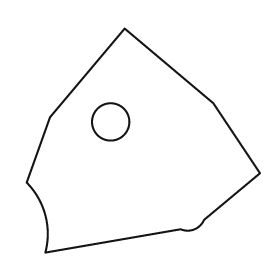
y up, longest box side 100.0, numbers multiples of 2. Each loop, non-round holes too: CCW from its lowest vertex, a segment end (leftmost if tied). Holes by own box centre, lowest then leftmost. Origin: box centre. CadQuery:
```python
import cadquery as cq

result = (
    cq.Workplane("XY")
    .moveTo(-42.0, -48.0)
    .lineTo(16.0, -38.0)
    .threePointArc((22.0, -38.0), (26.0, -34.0))
    .lineTo(50.0, -14.0)
    .lineTo(30.0, 16.0)
    .lineTo(-8.0, 48.0)
    .lineTo(-40.0, 10.0)
    .lineTo(-50.0, -18.0)
    .threePointArc((-42.0, -32.0), (-42.0, -48.0))
    .close()
    .moveTo(-14.0, 8.0)
    .circle(8.0)
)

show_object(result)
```